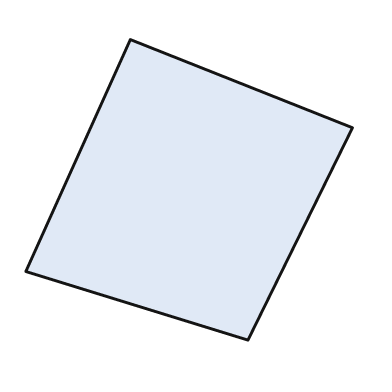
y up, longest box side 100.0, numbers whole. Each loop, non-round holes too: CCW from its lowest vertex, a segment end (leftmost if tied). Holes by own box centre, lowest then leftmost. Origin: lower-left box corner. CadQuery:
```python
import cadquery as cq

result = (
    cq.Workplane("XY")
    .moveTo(68.0, 0.0)
    .lineTo(100.0, 65.0)
    .lineTo(32.0, 92.0)
    .lineTo(0.0, 21.0)
    .close()
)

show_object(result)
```